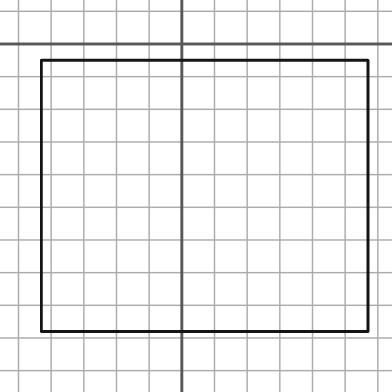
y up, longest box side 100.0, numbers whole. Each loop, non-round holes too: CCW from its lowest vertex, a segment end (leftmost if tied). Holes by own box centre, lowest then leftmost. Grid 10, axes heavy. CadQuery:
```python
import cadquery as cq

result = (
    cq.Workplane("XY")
    .moveTo(-43.0, -88.0)
    .lineTo(57.0, -88.0)
    .lineTo(57.0, -5.0)
    .lineTo(-43.0, -5.0)
    .close()
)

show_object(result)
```